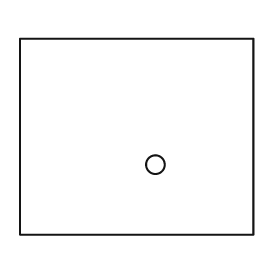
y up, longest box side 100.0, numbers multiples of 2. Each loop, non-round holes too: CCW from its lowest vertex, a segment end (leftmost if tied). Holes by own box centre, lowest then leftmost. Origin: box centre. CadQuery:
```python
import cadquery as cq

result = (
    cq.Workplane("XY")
    .moveTo(-50.0, -42.0)
    .lineTo(50.0, -42.0)
    .lineTo(50.0, 42.0)
    .lineTo(-50.0, 42.0)
    .close()
    .moveTo(8.0, -12.0)
    .circle(4.0)
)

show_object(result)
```